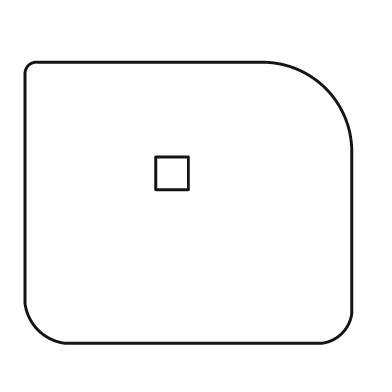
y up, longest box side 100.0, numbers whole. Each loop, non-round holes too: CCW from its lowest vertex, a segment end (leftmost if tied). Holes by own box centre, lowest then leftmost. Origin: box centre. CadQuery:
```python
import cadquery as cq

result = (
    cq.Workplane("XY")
    .moveTo(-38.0, -43.0)
    .lineTo(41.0, -43.0)
    .threePointArc((47.0, -40.0), (50.0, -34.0))
    .lineTo(50.0, 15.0)
    .threePointArc((42.0, 35.0), (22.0, 43.0))
    .lineTo(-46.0, 43.0)
    .threePointArc((-49.0, 42.0), (-50.0, 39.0))
    .lineTo(-50.0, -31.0)
    .threePointArc((-46.0, -39.0), (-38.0, -43.0))
    .close()
    .moveTo(-10.0, 4.0)
    .lineTo(0.0, 4.0)
    .lineTo(0.0, 14.0)
    .lineTo(-10.0, 14.0)
    .close()
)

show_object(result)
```